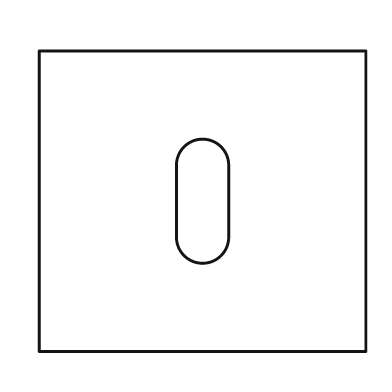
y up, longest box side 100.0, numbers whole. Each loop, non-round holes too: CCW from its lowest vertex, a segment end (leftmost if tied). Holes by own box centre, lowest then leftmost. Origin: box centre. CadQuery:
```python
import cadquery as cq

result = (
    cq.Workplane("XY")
    .moveTo(-50.0, -46.0)
    .lineTo(50.0, -46.0)
    .lineTo(50.0, 46.0)
    .lineTo(-50.0, 46.0)
    .close()
    .moveTo(-8.0, -11.0)
    .threePointArc((0.0, -19.0), (8.0, -11.0))
    .lineTo(8.0, 11.0)
    .threePointArc((0.0, 19.0), (-8.0, 11.0))
    .close()
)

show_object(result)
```